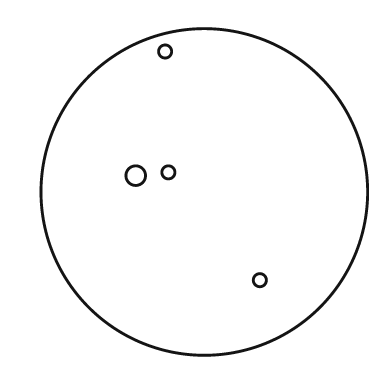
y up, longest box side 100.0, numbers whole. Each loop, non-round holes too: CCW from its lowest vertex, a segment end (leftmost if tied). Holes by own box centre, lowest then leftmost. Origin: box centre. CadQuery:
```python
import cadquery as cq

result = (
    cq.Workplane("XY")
    .moveTo(0.0, 0.0)
    .circle(50.0)
    .moveTo(17.0, -27.0)
    .circle(2.0)
    .moveTo(-21.0, 5.0)
    .circle(3.0)
    .moveTo(-11.0, 6.0)
    .circle(2.0)
    .moveTo(-12.0, 43.0)
    .circle(2.0)
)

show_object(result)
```